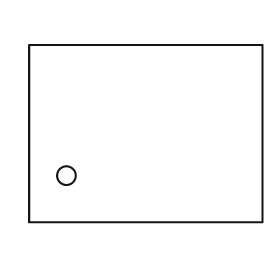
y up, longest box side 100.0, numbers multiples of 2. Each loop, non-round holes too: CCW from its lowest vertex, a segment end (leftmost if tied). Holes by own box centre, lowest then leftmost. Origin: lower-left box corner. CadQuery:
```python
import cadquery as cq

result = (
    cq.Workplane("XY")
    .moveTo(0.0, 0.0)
    .lineTo(100.0, 0.0)
    .lineTo(100.0, 76.0)
    .lineTo(0.0, 76.0)
    .close()
    .moveTo(16.0, 20.0)
    .circle(4.0)
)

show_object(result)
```